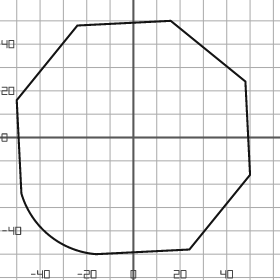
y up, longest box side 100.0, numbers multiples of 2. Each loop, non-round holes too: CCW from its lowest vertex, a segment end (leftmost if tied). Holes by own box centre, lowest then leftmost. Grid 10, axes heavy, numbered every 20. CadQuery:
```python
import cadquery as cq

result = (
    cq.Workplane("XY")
    .moveTo(-16.0, -50.0)
    .lineTo(24.0, -48.0)
    .lineTo(50.0, -16.0)
    .lineTo(48.0, 24.0)
    .lineTo(16.0, 50.0)
    .lineTo(-24.0, 48.0)
    .lineTo(-50.0, 16.0)
    .lineTo(-48.0, -24.0)
    .threePointArc((-36.0, -42.0), (-16.0, -50.0))
    .close()
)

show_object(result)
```